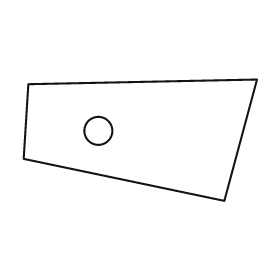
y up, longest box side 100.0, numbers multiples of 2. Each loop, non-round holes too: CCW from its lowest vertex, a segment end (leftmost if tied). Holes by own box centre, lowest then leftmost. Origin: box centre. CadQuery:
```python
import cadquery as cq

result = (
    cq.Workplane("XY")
    .moveTo(36.0, -26.0)
    .lineTo(50.0, 26.0)
    .lineTo(-48.0, 24.0)
    .lineTo(-50.0, -8.0)
    .close()
    .moveTo(-18.0, 4.0)
    .circle(6.0)
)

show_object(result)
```